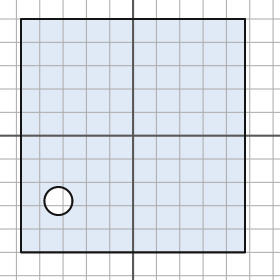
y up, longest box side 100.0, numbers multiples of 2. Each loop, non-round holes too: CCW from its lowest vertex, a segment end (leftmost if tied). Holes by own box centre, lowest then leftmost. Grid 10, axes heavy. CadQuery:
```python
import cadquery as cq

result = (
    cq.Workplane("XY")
    .moveTo(-48.0, -50.0)
    .lineTo(48.0, -50.0)
    .lineTo(48.0, 50.0)
    .lineTo(-48.0, 50.0)
    .close()
    .moveTo(-32.0, -28.0)
    .circle(6.0)
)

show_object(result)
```